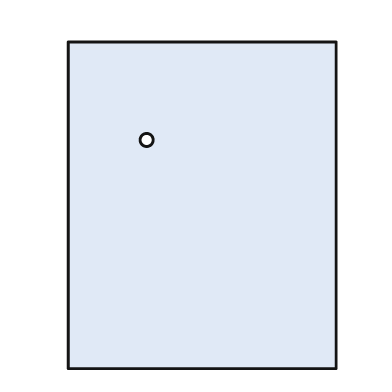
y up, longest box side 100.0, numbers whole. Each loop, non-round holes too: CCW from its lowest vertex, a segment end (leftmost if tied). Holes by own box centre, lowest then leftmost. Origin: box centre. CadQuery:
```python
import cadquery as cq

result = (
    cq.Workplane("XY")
    .moveTo(-41.0, -50.0)
    .lineTo(41.0, -50.0)
    .lineTo(41.0, 50.0)
    .lineTo(-41.0, 50.0)
    .close()
    .moveTo(-17.0, 20.0)
    .circle(2.0)
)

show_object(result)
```